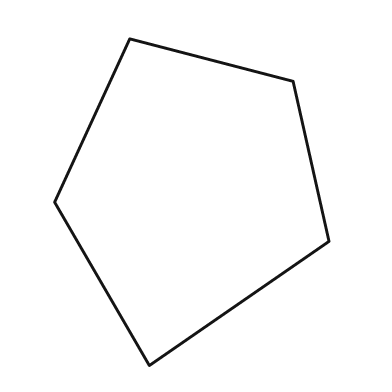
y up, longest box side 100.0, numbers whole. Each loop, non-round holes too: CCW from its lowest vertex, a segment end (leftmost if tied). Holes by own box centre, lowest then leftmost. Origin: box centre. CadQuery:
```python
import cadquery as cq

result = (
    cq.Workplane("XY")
    .moveTo(-13.0, -50.0)
    .lineTo(42.0, -12.0)
    .lineTo(31.0, 37.0)
    .lineTo(-19.0, 50.0)
    .lineTo(-42.0, 0.0)
    .close()
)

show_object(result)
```